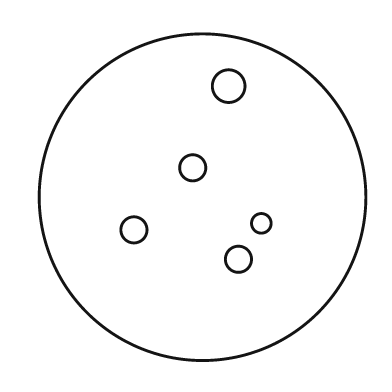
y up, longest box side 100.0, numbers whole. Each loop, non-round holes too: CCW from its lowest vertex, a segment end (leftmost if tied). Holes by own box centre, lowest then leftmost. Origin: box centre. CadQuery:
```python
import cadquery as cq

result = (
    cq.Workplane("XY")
    .moveTo(0.0, 0.0)
    .circle(50.0)
    .moveTo(11.0, -19.0)
    .circle(4.0)
    .moveTo(-21.0, -10.0)
    .circle(4.0)
    .moveTo(18.0, -8.0)
    .circle(3.0)
    .moveTo(-3.0, 9.0)
    .circle(4.0)
    .moveTo(8.0, 34.0)
    .circle(5.0)
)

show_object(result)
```